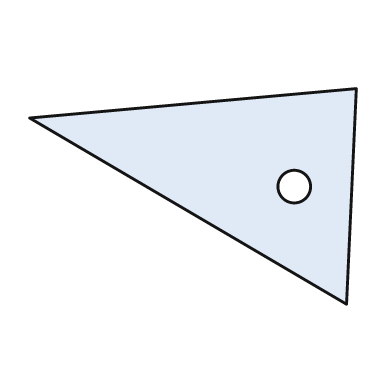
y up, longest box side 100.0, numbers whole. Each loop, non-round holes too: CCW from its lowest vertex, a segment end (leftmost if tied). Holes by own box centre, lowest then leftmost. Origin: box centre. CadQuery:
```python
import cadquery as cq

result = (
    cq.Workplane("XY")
    .moveTo(47.0, -33.0)
    .lineTo(50.0, 33.0)
    .lineTo(-50.0, 24.0)
    .close()
    .moveTo(31.0, 3.0)
    .circle(5.0)
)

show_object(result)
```